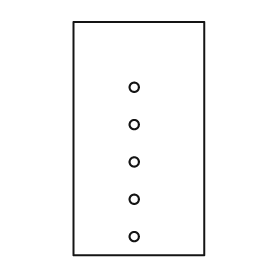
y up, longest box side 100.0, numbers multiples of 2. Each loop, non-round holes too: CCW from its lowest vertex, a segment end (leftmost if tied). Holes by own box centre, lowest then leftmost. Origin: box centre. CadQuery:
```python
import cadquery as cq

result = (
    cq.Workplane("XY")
    .moveTo(-28.0, -50.0)
    .lineTo(28.0, -50.0)
    .lineTo(28.0, 50.0)
    .lineTo(-28.0, 50.0)
    .close()
    .moveTo(-2.0, -42.0)
    .circle(2.0)
    .moveTo(-2.0, -26.0)
    .circle(2.0)
    .moveTo(-2.0, -10.0)
    .circle(2.0)
    .moveTo(-2.0, 6.0)
    .circle(2.0)
    .moveTo(-2.0, 22.0)
    .circle(2.0)
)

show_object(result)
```